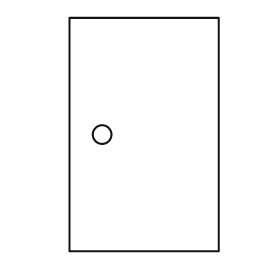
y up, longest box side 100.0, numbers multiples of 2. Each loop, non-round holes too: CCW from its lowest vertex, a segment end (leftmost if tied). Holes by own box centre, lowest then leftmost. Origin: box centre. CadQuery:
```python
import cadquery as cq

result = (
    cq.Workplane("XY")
    .moveTo(-32.0, -50.0)
    .lineTo(32.0, -50.0)
    .lineTo(32.0, 50.0)
    .lineTo(-32.0, 50.0)
    .close()
    .moveTo(-18.0, 0.0)
    .circle(4.0)
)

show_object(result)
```